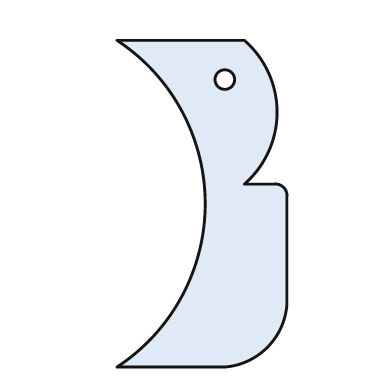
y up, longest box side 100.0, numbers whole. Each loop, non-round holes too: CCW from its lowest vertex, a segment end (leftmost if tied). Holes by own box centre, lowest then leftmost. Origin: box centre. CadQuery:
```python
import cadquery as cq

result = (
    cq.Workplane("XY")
    .moveTo(-26.0, -50.0)
    .lineTo(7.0, -50.0)
    .threePointArc((20.0, -44.0), (26.0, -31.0))
    .lineTo(26.0, 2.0)
    .threePointArc((25.0, 5.0), (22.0, 6.0))
    .lineTo(13.0, 6.0)
    .threePointArc((23.0, 28.0), (13.0, 50.0))
    .lineTo(-26.0, 50.0)
    .threePointArc((1.0, 0.0), (-26.0, -50.0))
    .close()
    .moveTo(7.0, 38.0)
    .circle(3.0)
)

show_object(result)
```